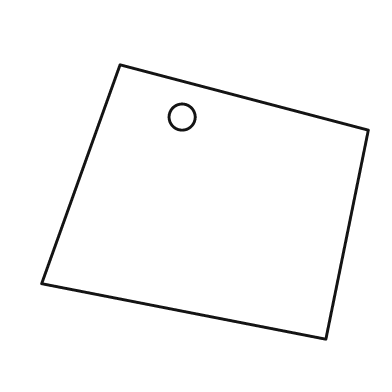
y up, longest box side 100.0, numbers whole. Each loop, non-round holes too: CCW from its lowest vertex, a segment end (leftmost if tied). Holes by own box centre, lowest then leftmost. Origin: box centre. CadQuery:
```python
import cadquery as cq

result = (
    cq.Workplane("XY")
    .moveTo(37.0, -42.0)
    .lineTo(50.0, 22.0)
    .lineTo(-26.0, 42.0)
    .lineTo(-50.0, -25.0)
    .close()
    .moveTo(-7.0, 26.0)
    .circle(4.0)
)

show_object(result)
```